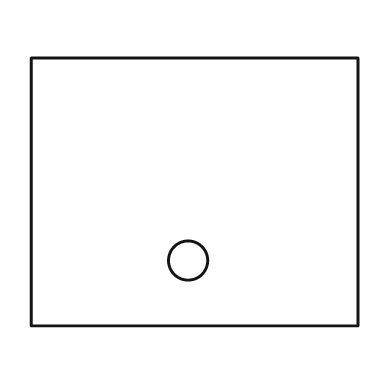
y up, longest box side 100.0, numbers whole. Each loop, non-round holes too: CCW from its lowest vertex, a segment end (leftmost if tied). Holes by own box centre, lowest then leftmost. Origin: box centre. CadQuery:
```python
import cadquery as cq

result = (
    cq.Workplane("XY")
    .moveTo(-50.0, -41.0)
    .lineTo(50.0, -41.0)
    .lineTo(50.0, 41.0)
    .lineTo(-50.0, 41.0)
    .close()
    .moveTo(-2.0, -21.0)
    .circle(6.0)
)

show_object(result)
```